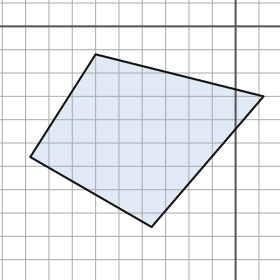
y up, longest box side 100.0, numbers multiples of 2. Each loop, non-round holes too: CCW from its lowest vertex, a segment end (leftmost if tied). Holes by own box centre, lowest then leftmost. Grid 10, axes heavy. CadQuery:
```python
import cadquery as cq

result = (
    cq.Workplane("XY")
    .moveTo(-36.0, -86.0)
    .lineTo(12.0, -30.0)
    .lineTo(-60.0, -12.0)
    .lineTo(-88.0, -56.0)
    .close()
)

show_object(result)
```